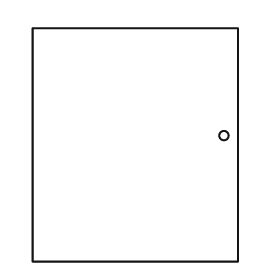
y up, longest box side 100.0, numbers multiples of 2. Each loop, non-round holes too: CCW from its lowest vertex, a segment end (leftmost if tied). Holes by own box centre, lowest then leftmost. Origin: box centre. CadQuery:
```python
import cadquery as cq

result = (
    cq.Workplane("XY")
    .moveTo(-44.0, -50.0)
    .lineTo(44.0, -50.0)
    .lineTo(44.0, 50.0)
    .lineTo(-44.0, 50.0)
    .close()
    .moveTo(38.0, 4.0)
    .circle(2.0)
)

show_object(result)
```